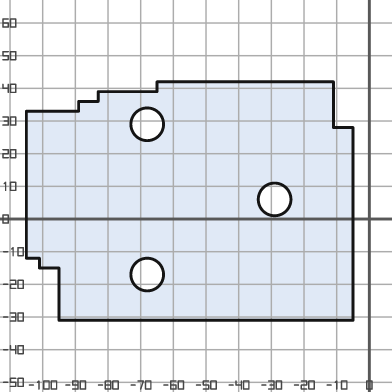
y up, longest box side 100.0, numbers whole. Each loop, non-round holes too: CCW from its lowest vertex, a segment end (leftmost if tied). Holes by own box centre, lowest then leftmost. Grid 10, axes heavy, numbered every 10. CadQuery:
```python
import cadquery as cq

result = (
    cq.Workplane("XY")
    .moveTo(-95.0, -31.0)
    .lineTo(-5.0, -31.0)
    .lineTo(-5.0, 28.0)
    .lineTo(-11.0, 28.0)
    .lineTo(-11.0, 42.0)
    .lineTo(-65.0, 42.0)
    .lineTo(-65.0, 39.0)
    .lineTo(-83.0, 39.0)
    .lineTo(-83.0, 36.0)
    .lineTo(-89.0, 36.0)
    .lineTo(-89.0, 33.0)
    .lineTo(-105.0, 33.0)
    .lineTo(-105.0, -12.0)
    .lineTo(-101.0, -12.0)
    .lineTo(-101.0, -15.0)
    .lineTo(-95.0, -15.0)
    .close()
    .moveTo(-68.0, -17.0)
    .circle(5.0)
    .moveTo(-29.0, 6.0)
    .circle(5.0)
    .moveTo(-68.0, 29.0)
    .circle(5.0)
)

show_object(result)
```